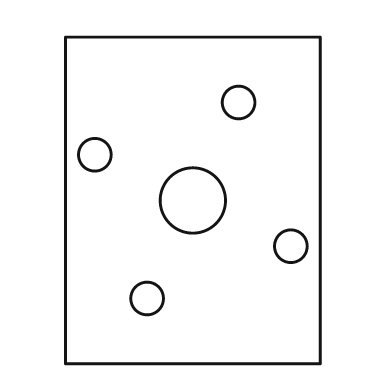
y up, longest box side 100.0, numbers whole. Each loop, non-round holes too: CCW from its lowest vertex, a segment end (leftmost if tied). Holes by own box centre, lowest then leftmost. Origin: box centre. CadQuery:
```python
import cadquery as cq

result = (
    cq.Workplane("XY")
    .moveTo(-39.0, -50.0)
    .lineTo(39.0, -50.0)
    .lineTo(39.0, 50.0)
    .lineTo(-39.0, 50.0)
    .close()
    .moveTo(-14.0, -30.0)
    .circle(5.0)
    .moveTo(30.0, -14.0)
    .circle(5.0)
    .moveTo(0.0, 0.0)
    .circle(10.0)
    .moveTo(-30.0, 14.0)
    .circle(5.0)
    .moveTo(14.0, 30.0)
    .circle(5.0)
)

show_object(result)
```